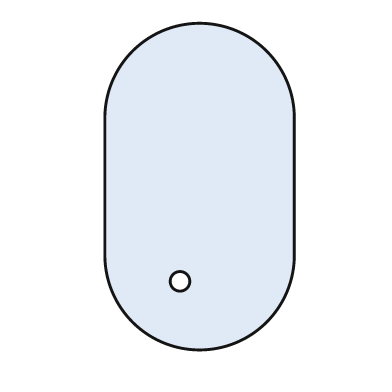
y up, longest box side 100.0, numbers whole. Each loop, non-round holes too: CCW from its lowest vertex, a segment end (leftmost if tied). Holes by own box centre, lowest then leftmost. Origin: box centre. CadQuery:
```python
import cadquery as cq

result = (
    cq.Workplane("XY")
    .moveTo(-29.0, -21.0)
    .threePointArc((0.0, -50.0), (29.0, -21.0))
    .lineTo(29.0, 21.0)
    .threePointArc((0.0, 50.0), (-29.0, 21.0))
    .close()
    .moveTo(-6.0, -29.0)
    .circle(3.0)
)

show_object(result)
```